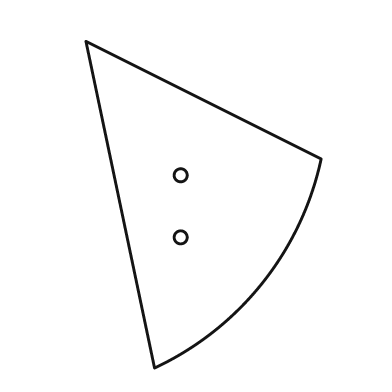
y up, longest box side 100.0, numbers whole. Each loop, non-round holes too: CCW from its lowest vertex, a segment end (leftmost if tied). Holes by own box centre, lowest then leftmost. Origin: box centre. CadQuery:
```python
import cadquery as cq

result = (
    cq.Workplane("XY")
    .moveTo(-15.0, -50.0)
    .threePointArc((18.0, -24.0), (36.0, 14.0))
    .lineTo(-36.0, 50.0)
    .close()
    .moveTo(-7.0, -10.0)
    .circle(2.0)
    .moveTo(-7.0, 9.0)
    .circle(2.0)
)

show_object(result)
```